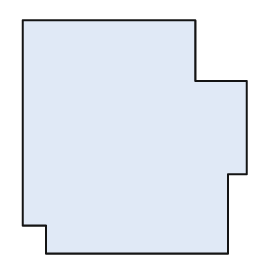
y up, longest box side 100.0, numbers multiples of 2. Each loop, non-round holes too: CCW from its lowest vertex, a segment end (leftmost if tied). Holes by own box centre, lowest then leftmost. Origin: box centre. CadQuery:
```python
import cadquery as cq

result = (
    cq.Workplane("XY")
    .moveTo(-38.0, -50.0)
    .lineTo(40.0, -50.0)
    .lineTo(40.0, -16.0)
    .lineTo(48.0, -16.0)
    .lineTo(48.0, 24.0)
    .lineTo(26.0, 24.0)
    .lineTo(26.0, 50.0)
    .lineTo(-48.0, 50.0)
    .lineTo(-48.0, -38.0)
    .lineTo(-38.0, -38.0)
    .close()
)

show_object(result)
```